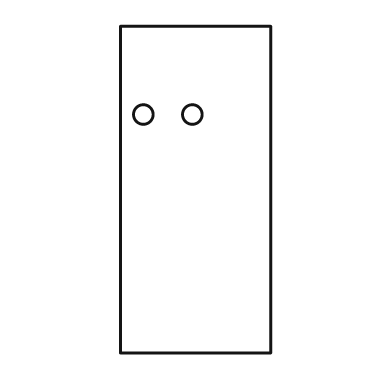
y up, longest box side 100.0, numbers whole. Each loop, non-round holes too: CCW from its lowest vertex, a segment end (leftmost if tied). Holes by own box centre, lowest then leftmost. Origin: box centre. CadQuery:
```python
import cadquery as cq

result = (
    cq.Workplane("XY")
    .moveTo(-23.0, -50.0)
    .lineTo(23.0, -50.0)
    .lineTo(23.0, 50.0)
    .lineTo(-23.0, 50.0)
    .close()
    .moveTo(-16.0, 23.0)
    .circle(3.0)
    .moveTo(-1.0, 23.0)
    .circle(3.0)
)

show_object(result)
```